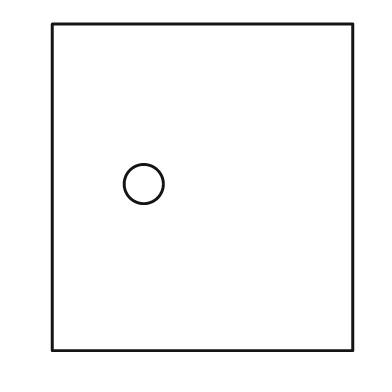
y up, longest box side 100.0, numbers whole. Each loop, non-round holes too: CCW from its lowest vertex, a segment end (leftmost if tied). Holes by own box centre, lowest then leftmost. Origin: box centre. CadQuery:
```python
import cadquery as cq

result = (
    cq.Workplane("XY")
    .moveTo(-46.0, -50.0)
    .lineTo(46.0, -50.0)
    .lineTo(46.0, 50.0)
    .lineTo(-46.0, 50.0)
    .close()
    .moveTo(-18.0, 1.0)
    .circle(6.0)
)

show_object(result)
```